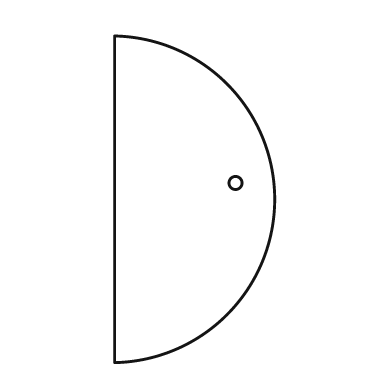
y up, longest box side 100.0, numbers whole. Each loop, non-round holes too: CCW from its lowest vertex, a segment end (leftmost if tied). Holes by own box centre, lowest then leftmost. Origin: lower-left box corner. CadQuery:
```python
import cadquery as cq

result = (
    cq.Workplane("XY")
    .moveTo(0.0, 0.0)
    .threePointArc((49.0, 50.0), (0.0, 100.0))
    .close()
    .moveTo(37.0, 55.0)
    .circle(2.0)
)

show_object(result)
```